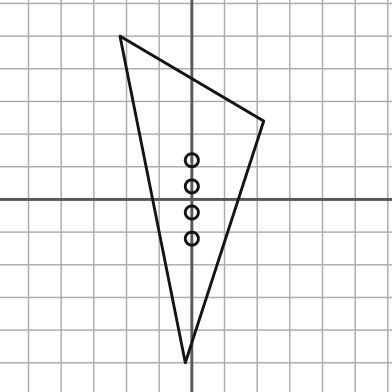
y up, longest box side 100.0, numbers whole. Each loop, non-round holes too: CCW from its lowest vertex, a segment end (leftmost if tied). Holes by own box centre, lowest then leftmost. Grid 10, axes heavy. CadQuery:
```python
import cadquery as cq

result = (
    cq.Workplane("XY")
    .moveTo(-2.0, -50.0)
    .lineTo(22.0, 24.0)
    .lineTo(-22.0, 50.0)
    .close()
    .moveTo(0.0, -12.0)
    .circle(2.0)
    .moveTo(0.0, -4.0)
    .circle(2.0)
    .moveTo(0.0, 4.0)
    .circle(2.0)
    .moveTo(0.0, 12.0)
    .circle(2.0)
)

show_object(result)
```